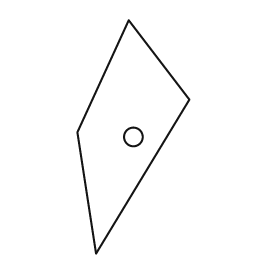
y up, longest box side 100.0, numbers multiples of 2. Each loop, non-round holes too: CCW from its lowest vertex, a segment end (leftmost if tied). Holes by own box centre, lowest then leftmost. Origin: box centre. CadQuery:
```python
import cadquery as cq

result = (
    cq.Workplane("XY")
    .moveTo(-16.0, -50.0)
    .lineTo(24.0, 16.0)
    .lineTo(-2.0, 50.0)
    .lineTo(-24.0, 2.0)
    .close()
    .moveTo(0.0, 0.0)
    .circle(4.0)
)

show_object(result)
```